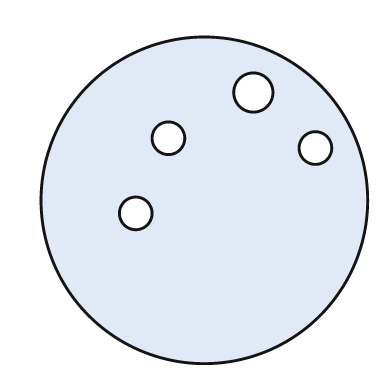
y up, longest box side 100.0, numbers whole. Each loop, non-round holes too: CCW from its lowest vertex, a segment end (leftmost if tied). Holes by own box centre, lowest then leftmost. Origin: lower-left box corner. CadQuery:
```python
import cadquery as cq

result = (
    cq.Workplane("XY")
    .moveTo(50.0, 50.0)
    .circle(50.0)
    .moveTo(29.0, 46.0)
    .circle(5.0)
    .moveTo(84.0, 66.0)
    .circle(5.0)
    .moveTo(39.0, 69.0)
    .circle(5.0)
    .moveTo(65.0, 83.0)
    .circle(6.0)
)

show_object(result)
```